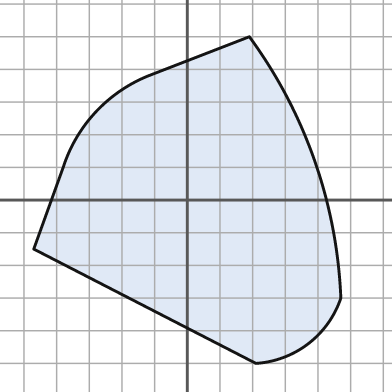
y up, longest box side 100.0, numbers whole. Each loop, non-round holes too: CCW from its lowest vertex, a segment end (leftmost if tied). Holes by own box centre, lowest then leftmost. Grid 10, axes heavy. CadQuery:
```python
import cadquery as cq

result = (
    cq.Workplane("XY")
    .moveTo(21.0, -50.0)
    .threePointArc((37.0, -44.0), (47.0, -30.0))
    .threePointArc((39.0, 12.0), (19.0, 50.0))
    .lineTo(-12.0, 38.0)
    .threePointArc((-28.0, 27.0), (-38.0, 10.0))
    .lineTo(-47.0, -15.0)
    .close()
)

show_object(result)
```